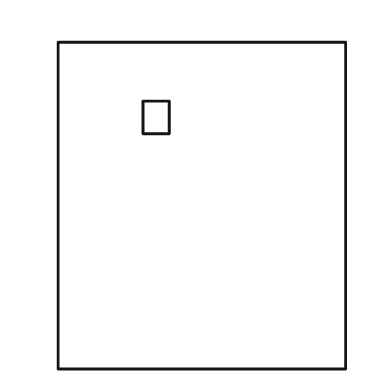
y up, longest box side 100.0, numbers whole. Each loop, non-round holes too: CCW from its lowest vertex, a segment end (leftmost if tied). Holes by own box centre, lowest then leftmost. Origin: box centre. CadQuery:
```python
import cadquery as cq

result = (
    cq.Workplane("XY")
    .moveTo(-44.0, -50.0)
    .lineTo(44.0, -50.0)
    .lineTo(44.0, 50.0)
    .lineTo(-44.0, 50.0)
    .close()
    .moveTo(-18.0, 22.0)
    .lineTo(-10.0, 22.0)
    .lineTo(-10.0, 32.0)
    .lineTo(-18.0, 32.0)
    .close()
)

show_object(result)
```